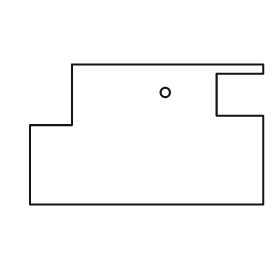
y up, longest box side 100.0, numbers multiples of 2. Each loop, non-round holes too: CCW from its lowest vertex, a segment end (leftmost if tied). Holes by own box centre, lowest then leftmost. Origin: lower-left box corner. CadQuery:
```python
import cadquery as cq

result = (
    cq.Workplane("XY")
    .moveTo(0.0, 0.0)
    .lineTo(100.0, 0.0)
    .lineTo(100.0, 38.0)
    .lineTo(80.0, 38.0)
    .lineTo(80.0, 56.0)
    .lineTo(100.0, 56.0)
    .lineTo(100.0, 60.0)
    .lineTo(18.0, 60.0)
    .lineTo(18.0, 34.0)
    .lineTo(0.0, 34.0)
    .close()
    .moveTo(58.0, 48.0)
    .circle(2.0)
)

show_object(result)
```